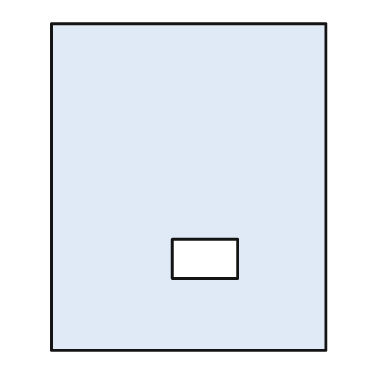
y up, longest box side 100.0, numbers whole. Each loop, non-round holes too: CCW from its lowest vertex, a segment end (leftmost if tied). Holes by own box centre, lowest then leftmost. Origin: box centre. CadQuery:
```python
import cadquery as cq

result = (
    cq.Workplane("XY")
    .moveTo(-42.0, -50.0)
    .lineTo(42.0, -50.0)
    .lineTo(42.0, 50.0)
    .lineTo(-42.0, 50.0)
    .close()
    .moveTo(-5.0, -28.0)
    .lineTo(15.0, -28.0)
    .lineTo(15.0, -16.0)
    .lineTo(-5.0, -16.0)
    .close()
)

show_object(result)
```